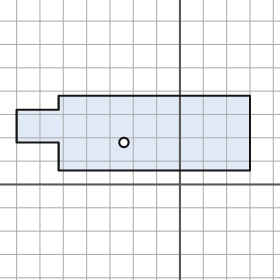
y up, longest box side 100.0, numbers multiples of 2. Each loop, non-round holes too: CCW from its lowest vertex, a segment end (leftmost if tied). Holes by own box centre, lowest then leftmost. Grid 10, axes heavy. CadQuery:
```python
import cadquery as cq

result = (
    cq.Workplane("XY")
    .moveTo(-52.0, 6.0)
    .lineTo(30.0, 6.0)
    .lineTo(30.0, 38.0)
    .lineTo(-52.0, 38.0)
    .lineTo(-52.0, 32.0)
    .lineTo(-70.0, 32.0)
    .lineTo(-70.0, 18.0)
    .lineTo(-52.0, 18.0)
    .close()
    .moveTo(-24.0, 18.0)
    .circle(2.0)
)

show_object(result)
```